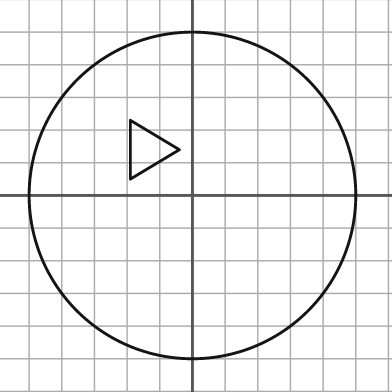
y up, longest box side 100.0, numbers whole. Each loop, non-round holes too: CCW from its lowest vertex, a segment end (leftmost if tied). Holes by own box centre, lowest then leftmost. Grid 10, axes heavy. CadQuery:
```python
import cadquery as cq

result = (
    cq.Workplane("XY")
    .moveTo(0.0, 0.0)
    .circle(50.0)
    .moveTo(-19.0, 5.0)
    .lineTo(-4.0, 14.0)
    .lineTo(-19.0, 23.0)
    .close()
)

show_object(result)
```